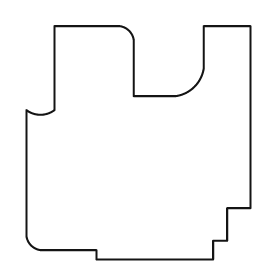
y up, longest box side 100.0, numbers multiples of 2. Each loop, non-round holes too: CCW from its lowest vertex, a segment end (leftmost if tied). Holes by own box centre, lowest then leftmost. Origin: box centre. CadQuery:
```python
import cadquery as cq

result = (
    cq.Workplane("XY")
    .moveTo(-18.0, -50.0)
    .lineTo(32.0, -50.0)
    .lineTo(32.0, -42.0)
    .lineTo(38.0, -42.0)
    .lineTo(38.0, -28.0)
    .lineTo(48.0, -28.0)
    .lineTo(48.0, 50.0)
    .lineTo(28.0, 50.0)
    .lineTo(28.0, 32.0)
    .threePointArc((24.0, 24.0), (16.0, 20.0))
    .lineTo(-2.0, 20.0)
    .lineTo(-2.0, 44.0)
    .threePointArc((-4.0, 48.0), (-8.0, 50.0))
    .lineTo(-36.0, 50.0)
    .lineTo(-36.0, 14.0)
    .threePointArc((-42.0, 12.0), (-48.0, 14.0))
    .lineTo(-48.0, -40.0)
    .threePointArc((-46.0, -44.0), (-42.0, -46.0))
    .lineTo(-18.0, -46.0)
    .close()
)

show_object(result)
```